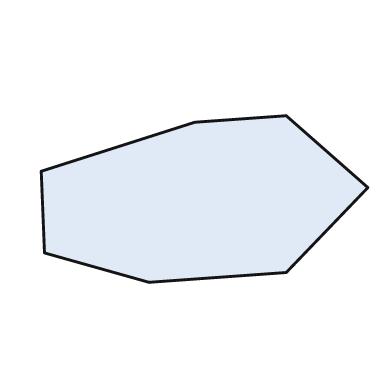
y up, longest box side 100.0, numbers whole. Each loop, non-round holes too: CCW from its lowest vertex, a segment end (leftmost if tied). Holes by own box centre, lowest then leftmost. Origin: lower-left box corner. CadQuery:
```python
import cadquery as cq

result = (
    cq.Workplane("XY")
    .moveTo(33.0, 0.0)
    .lineTo(75.0, 3.0)
    .lineTo(100.0, 29.0)
    .lineTo(75.0, 51.0)
    .lineTo(47.0, 49.0)
    .lineTo(0.0, 34.0)
    .lineTo(1.0, 9.0)
    .close()
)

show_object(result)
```